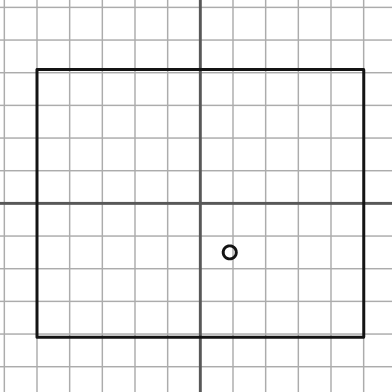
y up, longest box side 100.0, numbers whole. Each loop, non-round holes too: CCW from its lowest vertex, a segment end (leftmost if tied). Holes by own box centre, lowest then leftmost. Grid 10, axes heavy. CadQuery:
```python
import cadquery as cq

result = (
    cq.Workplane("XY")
    .moveTo(-50.0, -41.0)
    .lineTo(50.0, -41.0)
    .lineTo(50.0, 41.0)
    .lineTo(-50.0, 41.0)
    .close()
    .moveTo(9.0, -15.0)
    .circle(2.0)
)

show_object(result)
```